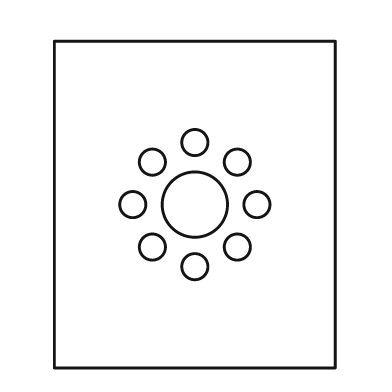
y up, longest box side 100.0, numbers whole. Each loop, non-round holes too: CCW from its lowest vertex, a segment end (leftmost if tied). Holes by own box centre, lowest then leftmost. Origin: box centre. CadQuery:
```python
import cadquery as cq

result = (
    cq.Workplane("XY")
    .moveTo(-43.0, -50.0)
    .lineTo(43.0, -50.0)
    .lineTo(43.0, 50.0)
    .lineTo(-43.0, 50.0)
    .close()
    .moveTo(0.0, -19.0)
    .circle(4.0)
    .moveTo(-13.0, -13.0)
    .circle(4.0)
    .moveTo(13.0, -13.0)
    .circle(4.0)
    .moveTo(-19.0, 0.0)
    .circle(4.0)
    .moveTo(0.0, 0.0)
    .circle(10.0)
    .moveTo(19.0, 0.0)
    .circle(4.0)
    .moveTo(-13.0, 13.0)
    .circle(4.0)
    .moveTo(13.0, 13.0)
    .circle(4.0)
    .moveTo(0.0, 19.0)
    .circle(4.0)
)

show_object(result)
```